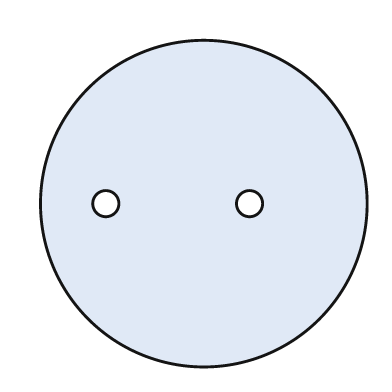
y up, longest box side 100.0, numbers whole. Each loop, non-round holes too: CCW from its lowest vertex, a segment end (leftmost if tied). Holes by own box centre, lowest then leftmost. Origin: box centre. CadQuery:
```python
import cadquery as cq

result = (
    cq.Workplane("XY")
    .moveTo(0.0, 0.0)
    .circle(50.0)
    .moveTo(-30.0, 0.0)
    .circle(4.0)
    .moveTo(14.0, 0.0)
    .circle(4.0)
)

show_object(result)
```